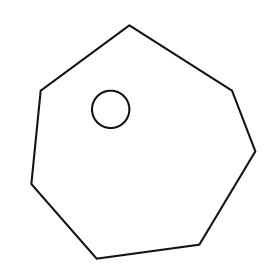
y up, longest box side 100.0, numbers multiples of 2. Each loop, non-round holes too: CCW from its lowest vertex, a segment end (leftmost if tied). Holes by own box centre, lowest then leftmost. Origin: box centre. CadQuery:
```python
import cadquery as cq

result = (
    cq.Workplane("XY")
    .moveTo(-20.0, -50.0)
    .lineTo(24.0, -44.0)
    .lineTo(48.0, -4.0)
    .lineTo(38.0, 22.0)
    .lineTo(-6.0, 50.0)
    .lineTo(-44.0, 22.0)
    .lineTo(-48.0, -18.0)
    .close()
    .moveTo(-14.0, 14.0)
    .circle(8.0)
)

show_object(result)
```